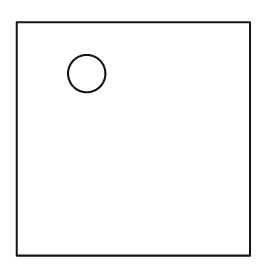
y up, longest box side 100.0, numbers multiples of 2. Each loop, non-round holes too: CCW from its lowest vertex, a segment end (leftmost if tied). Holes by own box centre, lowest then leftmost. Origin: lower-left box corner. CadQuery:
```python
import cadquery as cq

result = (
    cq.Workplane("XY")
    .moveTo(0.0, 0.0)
    .lineTo(100.0, 0.0)
    .lineTo(100.0, 100.0)
    .lineTo(0.0, 100.0)
    .close()
    .moveTo(30.0, 78.0)
    .circle(8.0)
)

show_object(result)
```